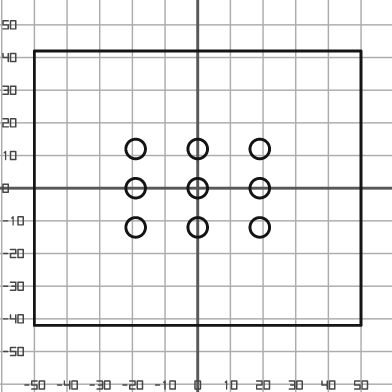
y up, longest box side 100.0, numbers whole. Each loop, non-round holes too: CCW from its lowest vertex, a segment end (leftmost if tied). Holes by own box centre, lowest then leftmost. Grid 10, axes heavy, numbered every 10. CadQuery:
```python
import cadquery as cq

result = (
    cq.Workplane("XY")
    .moveTo(-50.0, -42.0)
    .lineTo(50.0, -42.0)
    .lineTo(50.0, 42.0)
    .lineTo(-50.0, 42.0)
    .close()
    .moveTo(-19.0, -12.0)
    .circle(3.0)
    .moveTo(0.0, -12.0)
    .circle(3.0)
    .moveTo(19.0, -12.0)
    .circle(3.0)
    .moveTo(-19.0, 0.0)
    .circle(3.0)
    .moveTo(0.0, 0.0)
    .circle(3.0)
    .moveTo(19.0, 0.0)
    .circle(3.0)
    .moveTo(-19.0, 12.0)
    .circle(3.0)
    .moveTo(0.0, 12.0)
    .circle(3.0)
    .moveTo(19.0, 12.0)
    .circle(3.0)
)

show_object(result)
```